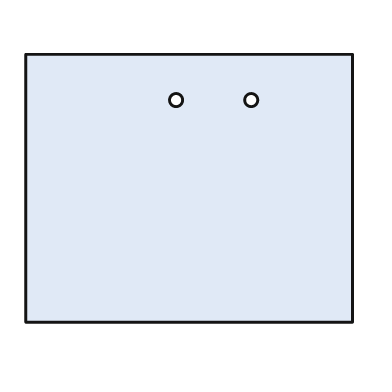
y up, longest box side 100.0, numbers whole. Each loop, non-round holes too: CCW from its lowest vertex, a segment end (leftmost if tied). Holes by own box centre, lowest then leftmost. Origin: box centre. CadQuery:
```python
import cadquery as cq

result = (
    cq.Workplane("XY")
    .moveTo(-50.0, -41.0)
    .lineTo(50.0, -41.0)
    .lineTo(50.0, 41.0)
    .lineTo(-50.0, 41.0)
    .close()
    .moveTo(-4.0, 27.0)
    .circle(2.0)
    .moveTo(19.0, 27.0)
    .circle(2.0)
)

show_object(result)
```